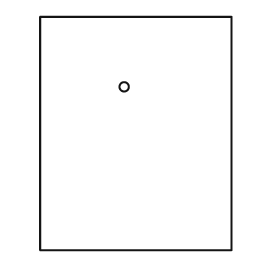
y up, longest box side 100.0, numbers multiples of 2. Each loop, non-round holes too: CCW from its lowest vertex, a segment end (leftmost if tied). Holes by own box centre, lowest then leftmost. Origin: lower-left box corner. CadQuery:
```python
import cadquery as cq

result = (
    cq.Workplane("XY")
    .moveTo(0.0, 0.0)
    .lineTo(82.0, 0.0)
    .lineTo(82.0, 100.0)
    .lineTo(0.0, 100.0)
    .close()
    .moveTo(36.0, 70.0)
    .circle(2.0)
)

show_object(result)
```